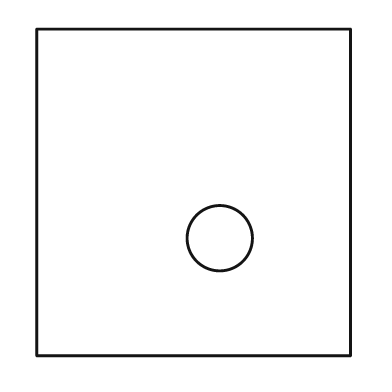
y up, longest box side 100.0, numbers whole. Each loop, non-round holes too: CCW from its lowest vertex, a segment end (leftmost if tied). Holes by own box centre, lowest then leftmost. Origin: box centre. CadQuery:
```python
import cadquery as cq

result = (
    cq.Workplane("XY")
    .moveTo(-48.0, -50.0)
    .lineTo(48.0, -50.0)
    .lineTo(48.0, 50.0)
    .lineTo(-48.0, 50.0)
    .close()
    .moveTo(8.0, -14.0)
    .circle(10.0)
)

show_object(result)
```